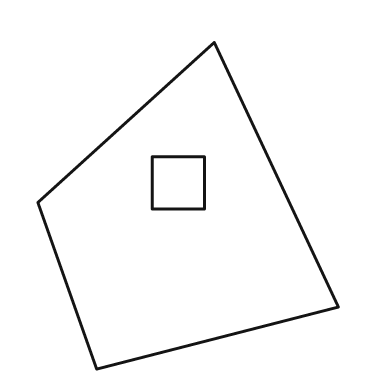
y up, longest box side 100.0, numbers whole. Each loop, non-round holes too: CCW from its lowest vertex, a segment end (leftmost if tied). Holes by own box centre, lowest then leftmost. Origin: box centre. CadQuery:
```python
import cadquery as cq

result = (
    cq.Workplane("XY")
    .moveTo(-28.0, -50.0)
    .lineTo(46.0, -31.0)
    .lineTo(8.0, 50.0)
    .lineTo(-46.0, 1.0)
    .close()
    .moveTo(-11.0, -1.0)
    .lineTo(5.0, -1.0)
    .lineTo(5.0, 15.0)
    .lineTo(-11.0, 15.0)
    .close()
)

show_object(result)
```